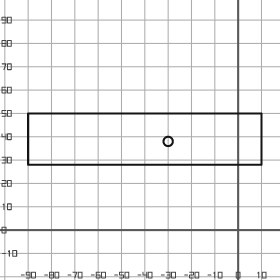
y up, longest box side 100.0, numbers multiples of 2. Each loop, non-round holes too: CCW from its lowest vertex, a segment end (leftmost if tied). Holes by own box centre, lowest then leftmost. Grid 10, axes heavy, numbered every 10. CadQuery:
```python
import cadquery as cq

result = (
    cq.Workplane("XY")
    .moveTo(-90.0, 28.0)
    .lineTo(10.0, 28.0)
    .lineTo(10.0, 50.0)
    .lineTo(-90.0, 50.0)
    .close()
    .moveTo(-30.0, 38.0)
    .circle(2.0)
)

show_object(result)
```